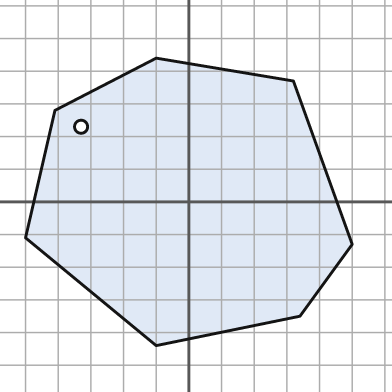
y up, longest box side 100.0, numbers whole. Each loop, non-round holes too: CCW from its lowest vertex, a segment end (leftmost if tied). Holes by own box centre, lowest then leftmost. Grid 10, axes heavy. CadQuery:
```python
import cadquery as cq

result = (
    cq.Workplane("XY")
    .moveTo(-10.0, -44.0)
    .lineTo(34.0, -35.0)
    .lineTo(50.0, -13.0)
    .lineTo(32.0, 37.0)
    .lineTo(-10.0, 44.0)
    .lineTo(-41.0, 28.0)
    .lineTo(-50.0, -11.0)
    .close()
    .moveTo(-33.0, 23.0)
    .circle(2.0)
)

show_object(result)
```